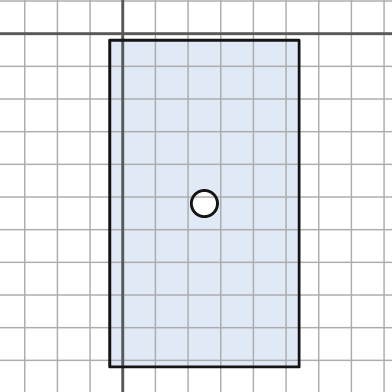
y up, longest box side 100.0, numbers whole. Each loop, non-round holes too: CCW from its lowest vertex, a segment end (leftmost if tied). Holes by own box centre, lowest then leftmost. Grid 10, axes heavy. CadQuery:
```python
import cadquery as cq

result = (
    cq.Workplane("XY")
    .moveTo(-4.0, -102.0)
    .lineTo(54.0, -102.0)
    .lineTo(54.0, -2.0)
    .lineTo(-4.0, -2.0)
    .close()
    .moveTo(25.0, -52.0)
    .circle(4.0)
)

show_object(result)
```